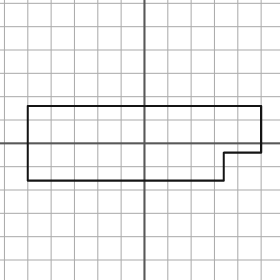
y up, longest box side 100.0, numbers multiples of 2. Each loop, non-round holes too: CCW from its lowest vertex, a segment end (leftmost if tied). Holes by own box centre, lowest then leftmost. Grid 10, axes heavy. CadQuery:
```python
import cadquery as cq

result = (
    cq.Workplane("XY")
    .moveTo(-50.0, -16.0)
    .lineTo(34.0, -16.0)
    .lineTo(34.0, -4.0)
    .lineTo(50.0, -4.0)
    .lineTo(50.0, 16.0)
    .lineTo(-50.0, 16.0)
    .close()
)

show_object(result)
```